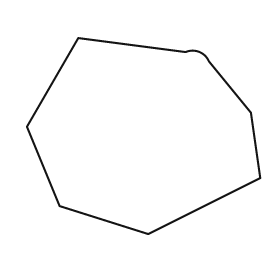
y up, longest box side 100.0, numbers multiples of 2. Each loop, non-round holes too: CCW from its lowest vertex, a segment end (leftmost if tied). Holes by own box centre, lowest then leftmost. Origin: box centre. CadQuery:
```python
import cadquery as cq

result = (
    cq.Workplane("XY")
    .moveTo(2.0, -42.0)
    .lineTo(50.0, -18.0)
    .lineTo(46.0, 10.0)
    .lineTo(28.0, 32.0)
    .threePointArc((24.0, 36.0), (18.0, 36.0))
    .lineTo(-28.0, 42.0)
    .lineTo(-50.0, 4.0)
    .lineTo(-36.0, -30.0)
    .close()
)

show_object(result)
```